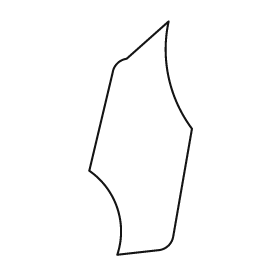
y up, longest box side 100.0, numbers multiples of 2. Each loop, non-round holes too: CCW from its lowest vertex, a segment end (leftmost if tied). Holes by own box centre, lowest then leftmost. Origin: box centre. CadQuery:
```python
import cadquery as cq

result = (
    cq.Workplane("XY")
    .moveTo(-10.0, -50.0)
    .lineTo(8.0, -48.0)
    .threePointArc((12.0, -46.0), (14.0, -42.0))
    .lineTo(22.0, 4.0)
    .threePointArc((12.0, 26.0), (12.0, 50.0))
    .lineTo(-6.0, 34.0)
    .threePointArc((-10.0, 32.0), (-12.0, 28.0))
    .lineTo(-22.0, -14.0)
    .threePointArc((-10.0, -30.0), (-10.0, -50.0))
    .close()
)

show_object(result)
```